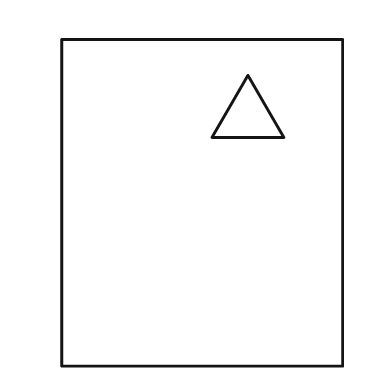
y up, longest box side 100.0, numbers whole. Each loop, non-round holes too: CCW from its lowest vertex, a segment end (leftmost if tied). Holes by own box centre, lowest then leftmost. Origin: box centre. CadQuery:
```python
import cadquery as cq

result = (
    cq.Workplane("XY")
    .moveTo(-43.0, -50.0)
    .lineTo(43.0, -50.0)
    .lineTo(43.0, 50.0)
    .lineTo(-43.0, 50.0)
    .close()
    .moveTo(3.0, 20.0)
    .lineTo(25.0, 20.0)
    .lineTo(14.0, 39.0)
    .close()
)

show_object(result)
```